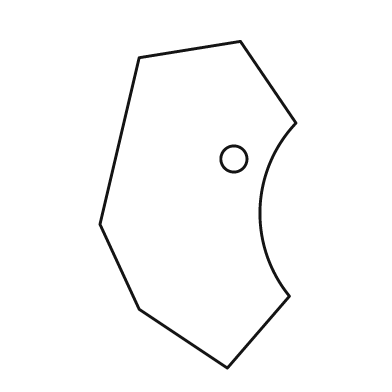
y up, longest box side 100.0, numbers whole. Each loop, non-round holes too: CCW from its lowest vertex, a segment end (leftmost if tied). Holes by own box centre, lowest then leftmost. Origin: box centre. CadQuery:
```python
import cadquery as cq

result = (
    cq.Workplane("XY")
    .moveTo(9.0, -50.0)
    .lineTo(28.0, -28.0)
    .threePointArc((19.0, -1.0), (30.0, 25.0))
    .lineTo(13.0, 50.0)
    .lineTo(-18.0, 45.0)
    .lineTo(-30.0, -6.0)
    .lineTo(-18.0, -32.0)
    .close()
    .moveTo(11.0, 14.0)
    .circle(4.0)
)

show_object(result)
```